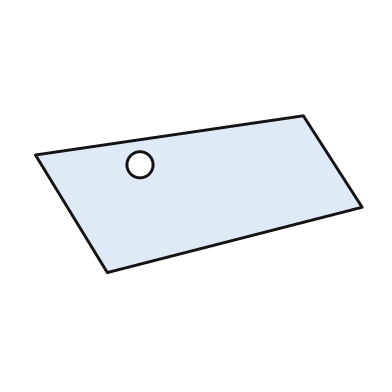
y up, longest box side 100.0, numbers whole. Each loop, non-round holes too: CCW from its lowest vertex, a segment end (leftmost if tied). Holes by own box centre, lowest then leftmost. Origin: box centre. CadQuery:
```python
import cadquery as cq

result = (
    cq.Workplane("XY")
    .moveTo(-28.0, -24.0)
    .lineTo(50.0, -4.0)
    .lineTo(32.0, 24.0)
    .lineTo(-50.0, 12.0)
    .close()
    .moveTo(-18.0, 9.0)
    .circle(4.0)
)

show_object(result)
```